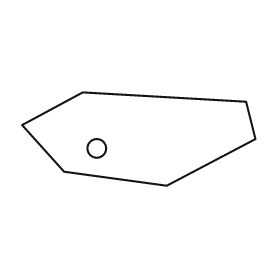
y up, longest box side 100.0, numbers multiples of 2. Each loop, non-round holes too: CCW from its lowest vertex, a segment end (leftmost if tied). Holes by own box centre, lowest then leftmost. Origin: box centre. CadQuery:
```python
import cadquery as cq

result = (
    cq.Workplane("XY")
    .moveTo(12.0, -20.0)
    .lineTo(50.0, 0.0)
    .lineTo(46.0, 16.0)
    .lineTo(-24.0, 20.0)
    .lineTo(-50.0, 6.0)
    .lineTo(-32.0, -14.0)
    .close()
    .moveTo(-18.0, -4.0)
    .circle(4.0)
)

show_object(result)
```